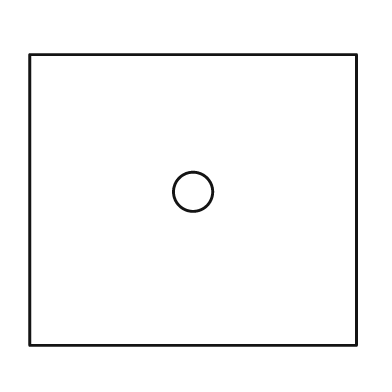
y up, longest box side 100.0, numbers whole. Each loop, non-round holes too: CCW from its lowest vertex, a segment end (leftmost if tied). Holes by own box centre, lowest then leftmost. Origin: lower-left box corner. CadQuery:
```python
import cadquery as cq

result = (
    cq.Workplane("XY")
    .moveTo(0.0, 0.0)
    .lineTo(100.0, 0.0)
    .lineTo(100.0, 89.0)
    .lineTo(0.0, 89.0)
    .close()
    .moveTo(50.0, 47.0)
    .circle(6.0)
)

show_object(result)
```